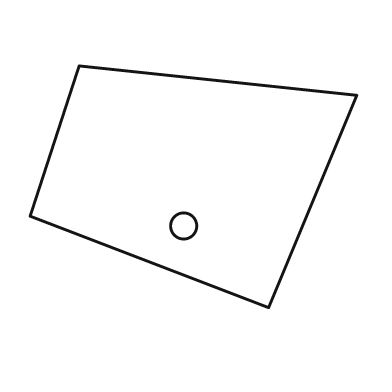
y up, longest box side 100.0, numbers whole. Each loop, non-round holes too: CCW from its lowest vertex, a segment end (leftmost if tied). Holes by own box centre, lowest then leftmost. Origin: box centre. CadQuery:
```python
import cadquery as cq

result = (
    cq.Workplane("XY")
    .moveTo(23.0, -37.0)
    .lineTo(50.0, 28.0)
    .lineTo(-35.0, 37.0)
    .lineTo(-50.0, -9.0)
    .close()
    .moveTo(-3.0, -12.0)
    .circle(4.0)
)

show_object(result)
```